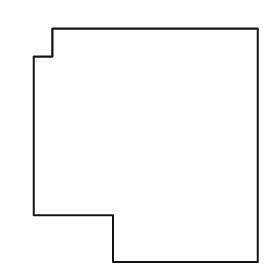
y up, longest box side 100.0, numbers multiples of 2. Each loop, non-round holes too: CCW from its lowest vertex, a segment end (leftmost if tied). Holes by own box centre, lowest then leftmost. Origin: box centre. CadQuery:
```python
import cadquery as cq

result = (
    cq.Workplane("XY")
    .moveTo(-14.0, -50.0)
    .lineTo(48.0, -50.0)
    .lineTo(48.0, 50.0)
    .lineTo(-40.0, 50.0)
    .lineTo(-40.0, 38.0)
    .lineTo(-48.0, 38.0)
    .lineTo(-48.0, -30.0)
    .lineTo(-14.0, -30.0)
    .close()
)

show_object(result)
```